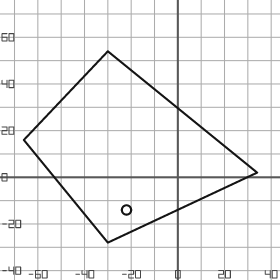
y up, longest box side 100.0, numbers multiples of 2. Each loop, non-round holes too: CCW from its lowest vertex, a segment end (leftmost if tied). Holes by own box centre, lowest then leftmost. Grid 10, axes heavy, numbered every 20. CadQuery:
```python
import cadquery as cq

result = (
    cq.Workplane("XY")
    .moveTo(-30.0, -28.0)
    .lineTo(34.0, 2.0)
    .lineTo(-30.0, 54.0)
    .lineTo(-66.0, 16.0)
    .close()
    .moveTo(-22.0, -14.0)
    .circle(2.0)
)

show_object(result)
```